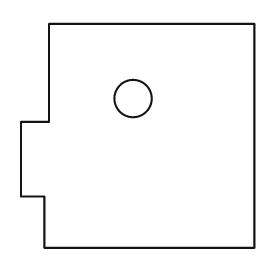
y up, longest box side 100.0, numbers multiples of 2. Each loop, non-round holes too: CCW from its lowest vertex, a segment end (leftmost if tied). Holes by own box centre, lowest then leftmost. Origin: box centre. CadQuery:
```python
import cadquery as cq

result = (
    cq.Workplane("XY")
    .moveTo(-40.0, -48.0)
    .lineTo(50.0, -48.0)
    .lineTo(50.0, 48.0)
    .lineTo(-38.0, 48.0)
    .lineTo(-38.0, 6.0)
    .lineTo(-50.0, 6.0)
    .lineTo(-50.0, -26.0)
    .lineTo(-40.0, -26.0)
    .close()
    .moveTo(-2.0, 16.0)
    .circle(8.0)
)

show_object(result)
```